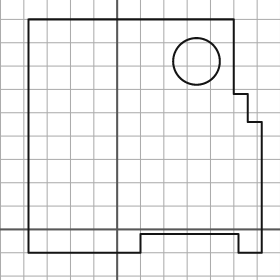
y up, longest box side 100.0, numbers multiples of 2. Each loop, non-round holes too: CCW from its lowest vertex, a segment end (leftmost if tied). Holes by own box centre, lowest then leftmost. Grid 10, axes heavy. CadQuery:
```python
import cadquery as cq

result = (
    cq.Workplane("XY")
    .moveTo(-38.0, -10.0)
    .lineTo(10.0, -10.0)
    .lineTo(10.0, -2.0)
    .lineTo(52.0, -2.0)
    .lineTo(52.0, -10.0)
    .lineTo(62.0, -10.0)
    .lineTo(62.0, 46.0)
    .lineTo(56.0, 46.0)
    .lineTo(56.0, 58.0)
    .lineTo(50.0, 58.0)
    .lineTo(50.0, 90.0)
    .lineTo(-38.0, 90.0)
    .close()
    .moveTo(34.0, 72.0)
    .circle(10.0)
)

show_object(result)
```